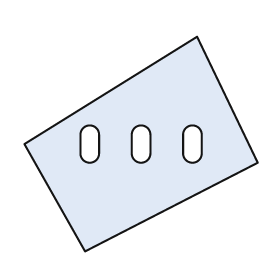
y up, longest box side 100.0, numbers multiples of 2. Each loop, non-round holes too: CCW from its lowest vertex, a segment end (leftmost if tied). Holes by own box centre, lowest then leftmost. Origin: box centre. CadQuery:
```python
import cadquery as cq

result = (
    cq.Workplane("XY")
    .moveTo(-24.0, -46.0)
    .lineTo(50.0, -8.0)
    .lineTo(24.0, 46.0)
    .lineTo(-50.0, 0.0)
    .close()
    .moveTo(-26.0, -4.0)
    .threePointArc((-22.0, -8.0), (-18.0, -4.0))
    .lineTo(-18.0, 4.0)
    .threePointArc((-22.0, 8.0), (-26.0, 4.0))
    .close()
    .moveTo(-4.0, -4.0)
    .threePointArc((0.0, -8.0), (4.0, -4.0))
    .lineTo(4.0, 4.0)
    .threePointArc((0.0, 8.0), (-4.0, 4.0))
    .close()
    .moveTo(18.0, -4.0)
    .threePointArc((22.0, -8.0), (26.0, -4.0))
    .lineTo(26.0, 4.0)
    .threePointArc((22.0, 8.0), (18.0, 4.0))
    .close()
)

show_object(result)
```